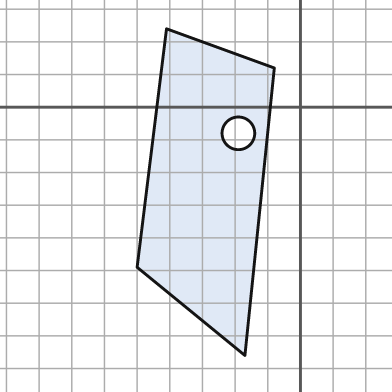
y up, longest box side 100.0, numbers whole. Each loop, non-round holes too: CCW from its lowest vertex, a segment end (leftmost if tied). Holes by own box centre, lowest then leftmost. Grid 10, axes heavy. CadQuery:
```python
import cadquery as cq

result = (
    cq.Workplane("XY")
    .moveTo(-17.0, -76.0)
    .lineTo(-8.0, 12.0)
    .lineTo(-41.0, 24.0)
    .lineTo(-50.0, -49.0)
    .close()
    .moveTo(-19.0, -8.0)
    .circle(5.0)
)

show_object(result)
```